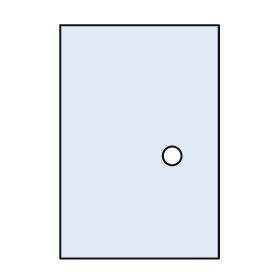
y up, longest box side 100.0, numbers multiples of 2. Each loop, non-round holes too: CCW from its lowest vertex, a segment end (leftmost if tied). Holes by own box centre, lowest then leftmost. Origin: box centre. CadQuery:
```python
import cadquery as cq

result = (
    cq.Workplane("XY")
    .moveTo(-34.0, -50.0)
    .lineTo(34.0, -50.0)
    .lineTo(34.0, 50.0)
    .lineTo(-34.0, 50.0)
    .close()
    .moveTo(14.0, -6.0)
    .circle(4.0)
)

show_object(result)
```